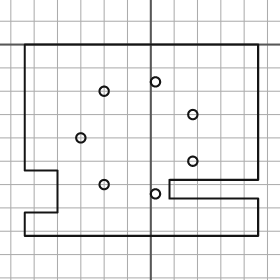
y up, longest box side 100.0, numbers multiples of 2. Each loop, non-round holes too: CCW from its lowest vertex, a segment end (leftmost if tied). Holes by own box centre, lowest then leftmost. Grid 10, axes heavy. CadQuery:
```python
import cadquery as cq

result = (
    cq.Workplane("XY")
    .moveTo(-54.0, -82.0)
    .lineTo(46.0, -82.0)
    .lineTo(46.0, -66.0)
    .lineTo(8.0, -66.0)
    .lineTo(8.0, -58.0)
    .lineTo(46.0, -58.0)
    .lineTo(46.0, 0.0)
    .lineTo(-54.0, 0.0)
    .lineTo(-54.0, -54.0)
    .lineTo(-40.0, -54.0)
    .lineTo(-40.0, -72.0)
    .lineTo(-54.0, -72.0)
    .close()
    .moveTo(2.0, -64.0)
    .circle(2.0)
    .moveTo(-20.0, -60.0)
    .circle(2.0)
    .moveTo(18.0, -50.0)
    .circle(2.0)
    .moveTo(-30.0, -40.0)
    .circle(2.0)
    .moveTo(18.0, -30.0)
    .circle(2.0)
    .moveTo(-20.0, -20.0)
    .circle(2.0)
    .moveTo(2.0, -16.0)
    .circle(2.0)
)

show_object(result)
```